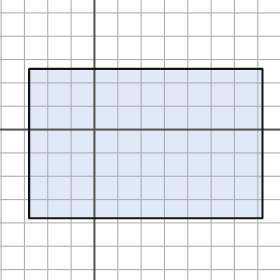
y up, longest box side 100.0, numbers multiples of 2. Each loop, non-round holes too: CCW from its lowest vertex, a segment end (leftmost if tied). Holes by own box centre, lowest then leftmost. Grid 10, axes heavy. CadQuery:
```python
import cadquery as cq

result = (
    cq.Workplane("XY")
    .moveTo(-28.0, -38.0)
    .lineTo(72.0, -38.0)
    .lineTo(72.0, 26.0)
    .lineTo(-28.0, 26.0)
    .close()
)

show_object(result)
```